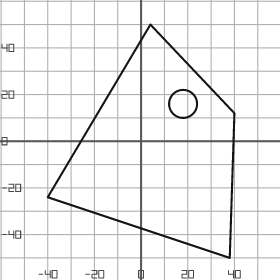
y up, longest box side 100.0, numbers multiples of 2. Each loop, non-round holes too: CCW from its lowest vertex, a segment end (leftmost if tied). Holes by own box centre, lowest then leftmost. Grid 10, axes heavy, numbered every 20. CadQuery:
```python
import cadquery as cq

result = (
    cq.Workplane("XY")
    .moveTo(38.0, -50.0)
    .lineTo(40.0, 12.0)
    .lineTo(4.0, 50.0)
    .lineTo(-40.0, -24.0)
    .close()
    .moveTo(18.0, 16.0)
    .circle(6.0)
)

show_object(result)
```